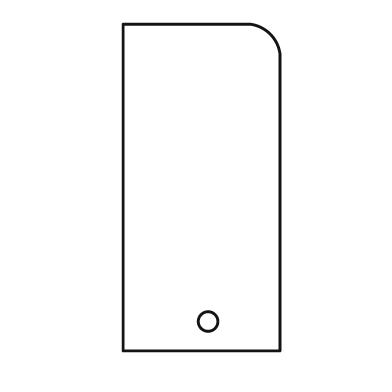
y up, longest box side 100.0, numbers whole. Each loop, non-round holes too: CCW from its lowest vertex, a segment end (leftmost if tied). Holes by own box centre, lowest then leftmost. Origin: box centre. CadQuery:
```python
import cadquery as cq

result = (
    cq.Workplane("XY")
    .moveTo(-24.0, -50.0)
    .lineTo(24.0, -50.0)
    .lineTo(24.0, 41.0)
    .threePointArc((21.0, 47.0), (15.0, 50.0))
    .lineTo(-24.0, 50.0)
    .close()
    .moveTo(2.0, -41.0)
    .circle(3.0)
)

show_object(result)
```